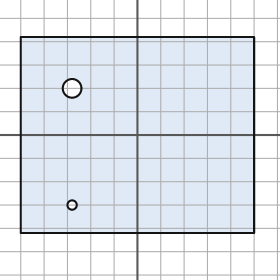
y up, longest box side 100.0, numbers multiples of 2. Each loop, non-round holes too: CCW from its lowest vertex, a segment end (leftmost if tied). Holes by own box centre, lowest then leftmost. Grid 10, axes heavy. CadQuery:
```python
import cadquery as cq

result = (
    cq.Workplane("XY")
    .moveTo(-50.0, -42.0)
    .lineTo(50.0, -42.0)
    .lineTo(50.0, 42.0)
    .lineTo(-50.0, 42.0)
    .close()
    .moveTo(-28.0, -30.0)
    .circle(2.0)
    .moveTo(-28.0, 20.0)
    .circle(4.0)
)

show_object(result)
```